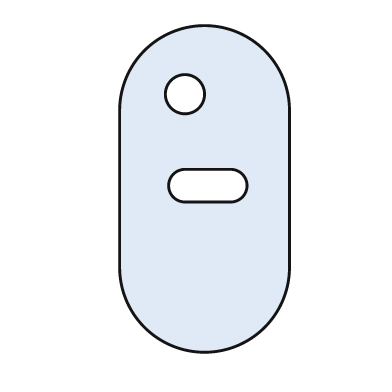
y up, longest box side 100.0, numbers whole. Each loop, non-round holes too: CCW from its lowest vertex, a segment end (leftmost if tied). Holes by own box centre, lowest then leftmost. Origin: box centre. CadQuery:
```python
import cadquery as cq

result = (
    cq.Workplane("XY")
    .moveTo(-26.0, -24.0)
    .threePointArc((0.0, -50.0), (26.0, -24.0))
    .lineTo(26.0, 24.0)
    .threePointArc((0.0, 50.0), (-26.0, 24.0))
    .close()
    .moveTo(-6.0, -4.0)
    .lineTo(8.0, -4.0)
    .threePointArc((13.0, 1.0), (8.0, 6.0))
    .lineTo(-6.0, 6.0)
    .threePointArc((-11.0, 1.0), (-6.0, -4.0))
    .close()
    .moveTo(-6.0, 29.0)
    .circle(6.0)
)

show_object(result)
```